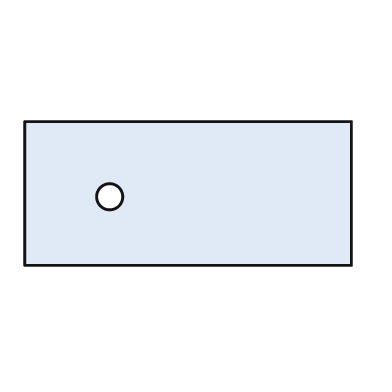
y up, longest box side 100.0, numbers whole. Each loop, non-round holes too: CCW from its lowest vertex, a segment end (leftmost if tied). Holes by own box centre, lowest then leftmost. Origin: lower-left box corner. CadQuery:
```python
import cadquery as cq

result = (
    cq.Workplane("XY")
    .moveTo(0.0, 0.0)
    .lineTo(100.0, 0.0)
    .lineTo(100.0, 44.0)
    .lineTo(0.0, 44.0)
    .close()
    .moveTo(26.0, 21.0)
    .circle(4.0)
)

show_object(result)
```